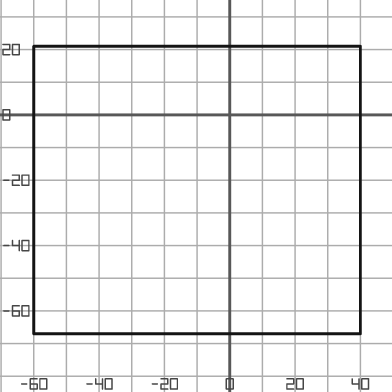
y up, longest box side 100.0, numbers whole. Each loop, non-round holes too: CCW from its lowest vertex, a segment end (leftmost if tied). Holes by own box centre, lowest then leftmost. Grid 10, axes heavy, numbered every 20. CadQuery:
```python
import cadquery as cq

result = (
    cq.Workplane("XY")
    .moveTo(-60.0, -67.0)
    .lineTo(40.0, -67.0)
    .lineTo(40.0, 21.0)
    .lineTo(-60.0, 21.0)
    .close()
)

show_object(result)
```